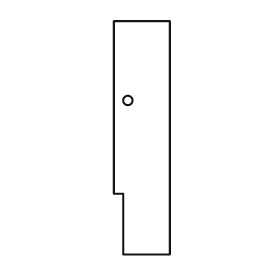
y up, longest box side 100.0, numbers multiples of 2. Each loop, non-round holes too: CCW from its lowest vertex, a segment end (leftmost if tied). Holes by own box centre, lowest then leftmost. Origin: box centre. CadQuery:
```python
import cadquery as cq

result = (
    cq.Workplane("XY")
    .moveTo(-8.0, -50.0)
    .lineTo(12.0, -50.0)
    .lineTo(12.0, 50.0)
    .lineTo(-12.0, 50.0)
    .lineTo(-12.0, -24.0)
    .lineTo(-8.0, -24.0)
    .close()
    .moveTo(-6.0, 16.0)
    .circle(2.0)
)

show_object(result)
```